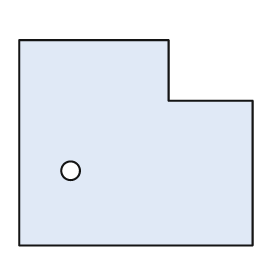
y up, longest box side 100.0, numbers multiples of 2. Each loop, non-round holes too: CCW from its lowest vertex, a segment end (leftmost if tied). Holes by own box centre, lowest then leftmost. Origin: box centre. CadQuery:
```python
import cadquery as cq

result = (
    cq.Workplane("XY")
    .moveTo(-50.0, -44.0)
    .lineTo(50.0, -44.0)
    .lineTo(50.0, 18.0)
    .lineTo(14.0, 18.0)
    .lineTo(14.0, 44.0)
    .lineTo(-50.0, 44.0)
    .close()
    .moveTo(-28.0, -12.0)
    .circle(4.0)
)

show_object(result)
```